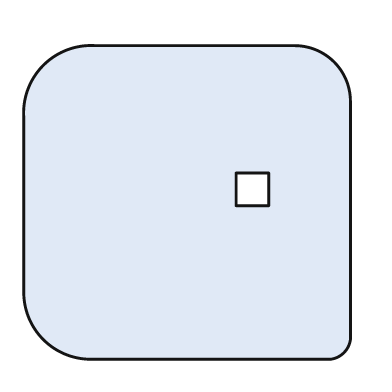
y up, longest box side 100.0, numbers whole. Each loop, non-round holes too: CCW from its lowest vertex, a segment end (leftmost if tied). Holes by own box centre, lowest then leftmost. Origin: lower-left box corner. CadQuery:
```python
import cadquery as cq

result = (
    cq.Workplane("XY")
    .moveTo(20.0, 0.0)
    .lineTo(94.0, 0.0)
    .threePointArc((98.0, 2.0), (100.0, 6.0))
    .lineTo(100.0, 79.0)
    .threePointArc((95.0, 91.0), (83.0, 96.0))
    .lineTo(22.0, 96.0)
    .threePointArc((6.0, 90.0), (0.0, 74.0))
    .lineTo(0.0, 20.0)
    .threePointArc((6.0, 6.0), (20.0, 0.0))
    .close()
    .moveTo(65.0, 47.0)
    .lineTo(75.0, 47.0)
    .lineTo(75.0, 57.0)
    .lineTo(65.0, 57.0)
    .close()
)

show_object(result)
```